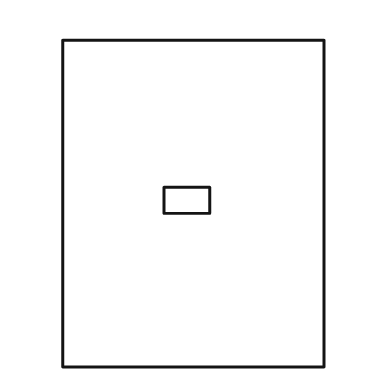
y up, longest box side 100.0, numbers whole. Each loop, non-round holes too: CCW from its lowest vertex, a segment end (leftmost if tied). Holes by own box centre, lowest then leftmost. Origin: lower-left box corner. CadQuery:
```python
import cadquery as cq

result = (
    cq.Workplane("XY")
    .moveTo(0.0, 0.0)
    .lineTo(80.0, 0.0)
    .lineTo(80.0, 100.0)
    .lineTo(0.0, 100.0)
    .close()
    .moveTo(31.0, 47.0)
    .lineTo(45.0, 47.0)
    .lineTo(45.0, 55.0)
    .lineTo(31.0, 55.0)
    .close()
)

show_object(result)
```